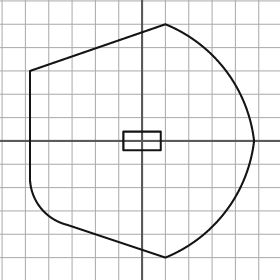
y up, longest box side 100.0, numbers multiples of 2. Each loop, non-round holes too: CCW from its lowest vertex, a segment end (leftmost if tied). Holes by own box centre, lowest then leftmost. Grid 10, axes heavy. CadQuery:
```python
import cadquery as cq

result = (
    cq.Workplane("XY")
    .moveTo(10.0, -50.0)
    .threePointArc((36.0, -30.0), (48.0, 0.0))
    .threePointArc((36.0, 30.0), (10.0, 50.0))
    .lineTo(-48.0, 30.0)
    .lineTo(-48.0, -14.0)
    .threePointArc((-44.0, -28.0), (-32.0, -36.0))
    .close()
    .moveTo(-8.0, -4.0)
    .lineTo(8.0, -4.0)
    .lineTo(8.0, 4.0)
    .lineTo(-8.0, 4.0)
    .close()
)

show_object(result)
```